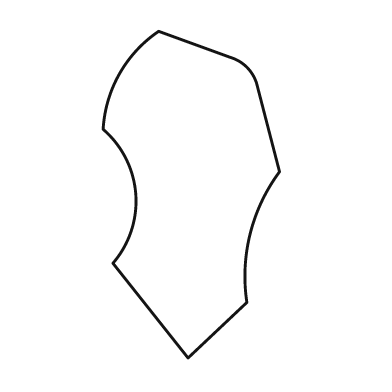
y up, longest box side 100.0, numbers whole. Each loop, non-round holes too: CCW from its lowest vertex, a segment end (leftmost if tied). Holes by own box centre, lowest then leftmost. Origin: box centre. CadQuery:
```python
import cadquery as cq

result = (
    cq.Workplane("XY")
    .moveTo(-1.0, -50.0)
    .lineTo(17.0, -33.0)
    .threePointArc((18.0, -12.0), (27.0, 7.0))
    .lineTo(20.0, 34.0)
    .threePointArc((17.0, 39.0), (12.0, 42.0))
    .lineTo(-10.0, 50.0)
    .threePointArc((-22.0, 37.0), (-27.0, 20.0))
    .threePointArc((-17.0, 0.0), (-24.0, -21.0))
    .close()
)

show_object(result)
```